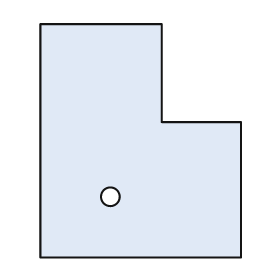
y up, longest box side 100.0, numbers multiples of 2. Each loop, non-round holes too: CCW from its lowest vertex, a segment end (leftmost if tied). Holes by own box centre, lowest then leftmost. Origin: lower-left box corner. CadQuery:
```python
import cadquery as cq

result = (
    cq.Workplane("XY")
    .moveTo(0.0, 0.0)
    .lineTo(86.0, 0.0)
    .lineTo(86.0, 58.0)
    .lineTo(52.0, 58.0)
    .lineTo(52.0, 100.0)
    .lineTo(0.0, 100.0)
    .close()
    .moveTo(30.0, 26.0)
    .circle(4.0)
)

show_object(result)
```